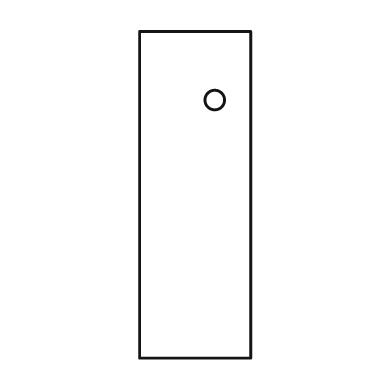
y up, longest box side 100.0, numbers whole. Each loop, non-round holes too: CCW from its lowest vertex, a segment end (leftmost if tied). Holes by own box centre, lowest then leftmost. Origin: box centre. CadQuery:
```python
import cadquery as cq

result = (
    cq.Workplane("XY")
    .moveTo(-17.0, -50.0)
    .lineTo(17.0, -50.0)
    .lineTo(17.0, 50.0)
    .lineTo(-17.0, 50.0)
    .close()
    .moveTo(6.0, 29.0)
    .circle(3.0)
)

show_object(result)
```